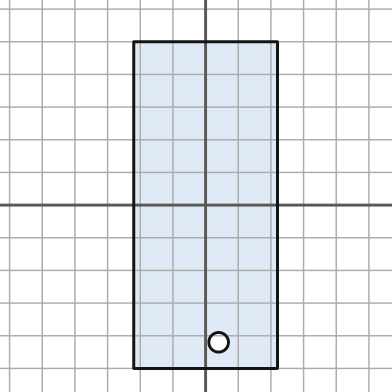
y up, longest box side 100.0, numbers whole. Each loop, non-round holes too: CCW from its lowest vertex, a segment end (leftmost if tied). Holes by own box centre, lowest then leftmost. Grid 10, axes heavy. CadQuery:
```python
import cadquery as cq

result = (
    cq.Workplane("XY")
    .moveTo(-22.0, -50.0)
    .lineTo(22.0, -50.0)
    .lineTo(22.0, 50.0)
    .lineTo(-22.0, 50.0)
    .close()
    .moveTo(4.0, -42.0)
    .circle(3.0)
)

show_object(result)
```